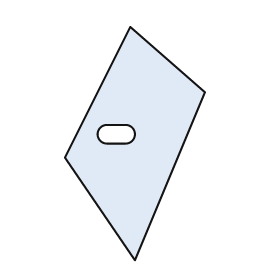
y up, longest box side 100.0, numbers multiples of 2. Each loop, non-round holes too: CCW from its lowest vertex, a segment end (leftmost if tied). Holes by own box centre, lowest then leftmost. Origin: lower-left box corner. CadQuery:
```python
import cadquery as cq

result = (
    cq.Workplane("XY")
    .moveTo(30.0, 0.0)
    .lineTo(60.0, 72.0)
    .lineTo(28.0, 100.0)
    .lineTo(0.0, 44.0)
    .close()
    .moveTo(18.0, 50.0)
    .lineTo(26.0, 50.0)
    .threePointArc((30.0, 54.0), (26.0, 58.0))
    .lineTo(18.0, 58.0)
    .threePointArc((14.0, 54.0), (18.0, 50.0))
    .close()
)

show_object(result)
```